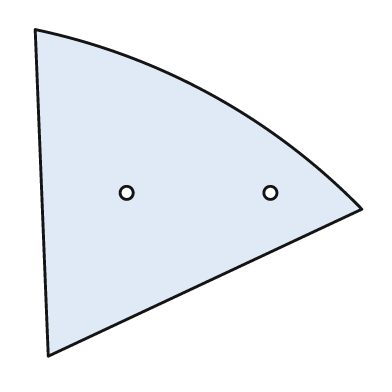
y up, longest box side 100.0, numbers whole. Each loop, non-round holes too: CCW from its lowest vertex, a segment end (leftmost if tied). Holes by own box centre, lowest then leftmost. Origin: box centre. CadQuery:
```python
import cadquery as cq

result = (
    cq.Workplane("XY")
    .moveTo(-46.0, -50.0)
    .lineTo(50.0, -5.0)
    .threePointArc((4.0, 30.0), (-50.0, 50.0))
    .close()
    .moveTo(-22.0, 0.0)
    .circle(2.0)
    .moveTo(22.0, 0.0)
    .circle(2.0)
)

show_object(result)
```